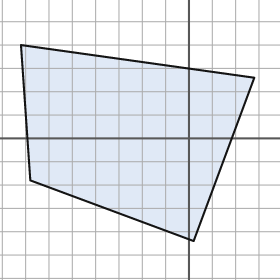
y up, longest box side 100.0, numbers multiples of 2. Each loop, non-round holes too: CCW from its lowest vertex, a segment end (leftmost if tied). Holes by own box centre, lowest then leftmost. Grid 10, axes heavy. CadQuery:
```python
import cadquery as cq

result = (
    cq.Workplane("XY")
    .moveTo(2.0, -44.0)
    .lineTo(28.0, 26.0)
    .lineTo(-72.0, 40.0)
    .lineTo(-68.0, -18.0)
    .close()
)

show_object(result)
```